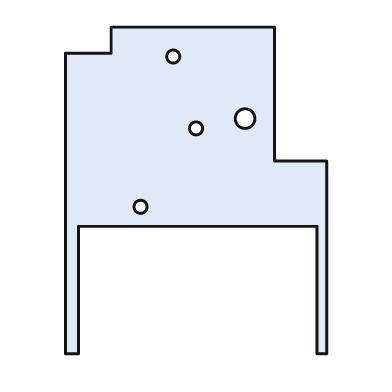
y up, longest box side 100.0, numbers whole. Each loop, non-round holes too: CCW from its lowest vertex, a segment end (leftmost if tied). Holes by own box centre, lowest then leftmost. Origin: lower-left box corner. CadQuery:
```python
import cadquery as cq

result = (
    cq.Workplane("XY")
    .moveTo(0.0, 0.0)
    .lineTo(4.0, 0.0)
    .lineTo(4.0, 39.0)
    .lineTo(77.0, 39.0)
    .lineTo(77.0, 0.0)
    .lineTo(80.0, 0.0)
    .lineTo(80.0, 59.0)
    .lineTo(64.0, 59.0)
    .lineTo(64.0, 100.0)
    .lineTo(14.0, 100.0)
    .lineTo(14.0, 92.0)
    .lineTo(0.0, 92.0)
    .close()
    .moveTo(23.0, 45.0)
    .circle(2.0)
    .moveTo(40.0, 69.0)
    .circle(2.0)
    .moveTo(55.0, 72.0)
    .circle(3.0)
    .moveTo(33.0, 91.0)
    .circle(2.0)
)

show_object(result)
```